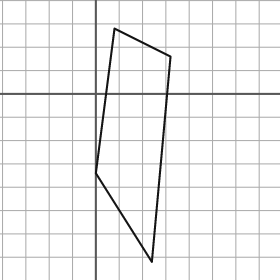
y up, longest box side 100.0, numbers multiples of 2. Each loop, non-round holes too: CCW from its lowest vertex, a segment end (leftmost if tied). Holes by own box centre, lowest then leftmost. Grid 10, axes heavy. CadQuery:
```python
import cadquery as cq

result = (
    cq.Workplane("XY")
    .moveTo(24.0, -72.0)
    .lineTo(32.0, 16.0)
    .lineTo(8.0, 28.0)
    .lineTo(0.0, -34.0)
    .close()
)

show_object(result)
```